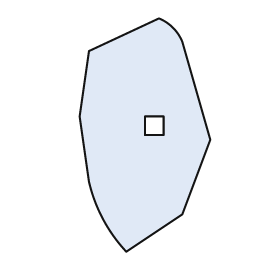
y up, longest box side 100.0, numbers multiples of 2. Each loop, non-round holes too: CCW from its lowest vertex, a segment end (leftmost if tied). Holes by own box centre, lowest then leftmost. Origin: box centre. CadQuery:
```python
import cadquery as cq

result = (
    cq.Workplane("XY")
    .moveTo(-8.0, -50.0)
    .lineTo(16.0, -34.0)
    .lineTo(28.0, -2.0)
    .lineTo(16.0, 40.0)
    .threePointArc((12.0, 46.0), (6.0, 50.0))
    .lineTo(-24.0, 36.0)
    .lineTo(-28.0, 8.0)
    .lineTo(-24.0, -20.0)
    .threePointArc((-18.0, -36.0), (-8.0, -50.0))
    .close()
    .moveTo(0.0, 0.0)
    .lineTo(8.0, 0.0)
    .lineTo(8.0, 8.0)
    .lineTo(0.0, 8.0)
    .close()
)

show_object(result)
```